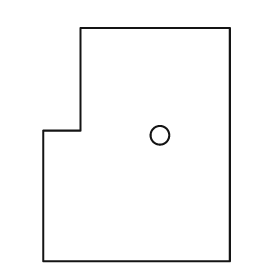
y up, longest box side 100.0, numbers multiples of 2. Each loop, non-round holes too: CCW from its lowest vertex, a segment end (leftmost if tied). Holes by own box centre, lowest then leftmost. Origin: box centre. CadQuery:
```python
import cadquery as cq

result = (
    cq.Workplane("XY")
    .moveTo(-40.0, -50.0)
    .lineTo(40.0, -50.0)
    .lineTo(40.0, 50.0)
    .lineTo(-24.0, 50.0)
    .lineTo(-24.0, 6.0)
    .lineTo(-40.0, 6.0)
    .close()
    .moveTo(10.0, 4.0)
    .circle(4.0)
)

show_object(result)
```